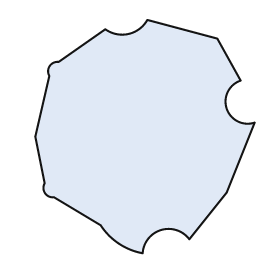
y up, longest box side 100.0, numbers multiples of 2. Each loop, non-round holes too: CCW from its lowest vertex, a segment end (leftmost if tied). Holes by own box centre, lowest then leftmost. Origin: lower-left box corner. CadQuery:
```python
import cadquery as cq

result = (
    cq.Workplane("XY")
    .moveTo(46.0, 0.0)
    .threePointArc((54.0, 10.0), (66.0, 6.0))
    .lineTo(82.0, 26.0)
    .lineTo(94.0, 56.0)
    .threePointArc((82.0, 62.0), (88.0, 74.0))
    .lineTo(78.0, 92.0)
    .lineTo(48.0, 100.0)
    .threePointArc((40.0, 94.0), (30.0, 96.0))
    .lineTo(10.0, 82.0)
    .threePointArc((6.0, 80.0), (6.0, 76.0))
    .lineTo(0.0, 50.0)
    .lineTo(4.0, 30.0)
    .threePointArc((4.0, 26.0), (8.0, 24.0))
    .lineTo(28.0, 12.0)
    .threePointArc((36.0, 4.0), (46.0, 0.0))
    .close()
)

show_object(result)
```